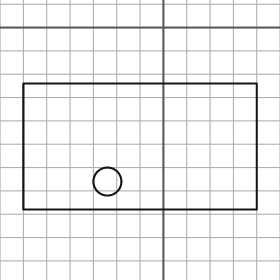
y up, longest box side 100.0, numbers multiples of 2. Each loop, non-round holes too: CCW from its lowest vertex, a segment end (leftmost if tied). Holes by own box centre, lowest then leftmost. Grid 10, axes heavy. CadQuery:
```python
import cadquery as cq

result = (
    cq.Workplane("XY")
    .moveTo(-60.0, -78.0)
    .lineTo(40.0, -78.0)
    .lineTo(40.0, -24.0)
    .lineTo(-60.0, -24.0)
    .close()
    .moveTo(-24.0, -66.0)
    .circle(6.0)
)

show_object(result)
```